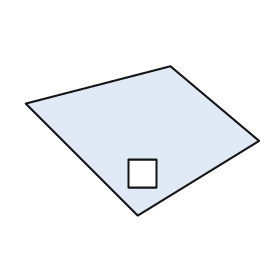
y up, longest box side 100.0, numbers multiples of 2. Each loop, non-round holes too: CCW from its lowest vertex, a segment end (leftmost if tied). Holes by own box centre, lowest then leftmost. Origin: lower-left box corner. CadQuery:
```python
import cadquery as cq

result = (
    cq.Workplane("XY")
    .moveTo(48.0, 0.0)
    .lineTo(100.0, 32.0)
    .lineTo(62.0, 64.0)
    .lineTo(0.0, 48.0)
    .close()
    .moveTo(44.0, 12.0)
    .lineTo(56.0, 12.0)
    .lineTo(56.0, 24.0)
    .lineTo(44.0, 24.0)
    .close()
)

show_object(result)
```